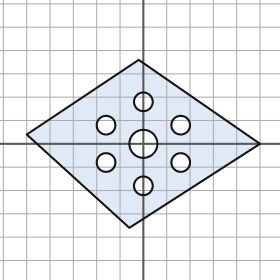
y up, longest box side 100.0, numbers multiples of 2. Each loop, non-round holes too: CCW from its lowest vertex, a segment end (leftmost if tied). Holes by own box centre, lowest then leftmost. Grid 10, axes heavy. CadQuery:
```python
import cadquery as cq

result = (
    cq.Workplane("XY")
    .moveTo(-6.0, -36.0)
    .lineTo(50.0, 0.0)
    .lineTo(-2.0, 36.0)
    .lineTo(-50.0, 4.0)
    .close()
    .moveTo(0.0, -18.0)
    .circle(4.0)
    .moveTo(-16.0, -8.0)
    .circle(4.0)
    .moveTo(16.0, -8.0)
    .circle(4.0)
    .moveTo(0.0, 0.0)
    .circle(6.0)
    .moveTo(-16.0, 8.0)
    .circle(4.0)
    .moveTo(16.0, 8.0)
    .circle(4.0)
    .moveTo(0.0, 18.0)
    .circle(4.0)
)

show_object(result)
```